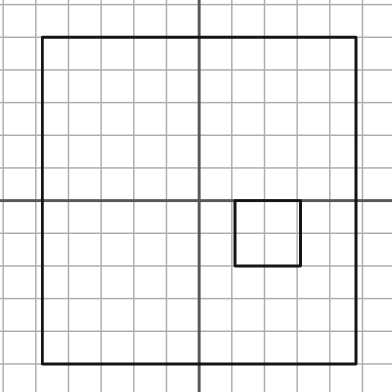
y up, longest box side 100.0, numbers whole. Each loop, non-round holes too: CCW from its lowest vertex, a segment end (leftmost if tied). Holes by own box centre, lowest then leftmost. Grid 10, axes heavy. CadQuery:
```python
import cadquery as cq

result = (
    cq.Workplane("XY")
    .moveTo(-48.0, -50.0)
    .lineTo(48.0, -50.0)
    .lineTo(48.0, 50.0)
    .lineTo(-48.0, 50.0)
    .close()
    .moveTo(11.0, -20.0)
    .lineTo(31.0, -20.0)
    .lineTo(31.0, 0.0)
    .lineTo(11.0, 0.0)
    .close()
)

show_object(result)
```